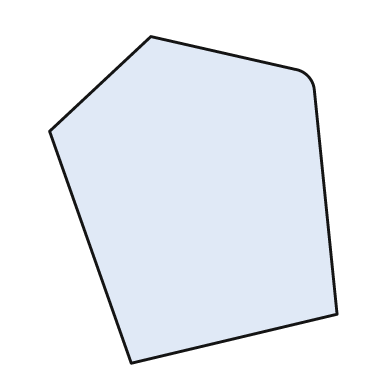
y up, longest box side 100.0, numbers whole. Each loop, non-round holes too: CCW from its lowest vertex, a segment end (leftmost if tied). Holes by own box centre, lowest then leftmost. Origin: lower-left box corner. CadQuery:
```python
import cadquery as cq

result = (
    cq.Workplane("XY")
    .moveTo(25.0, 0.0)
    .lineTo(88.0, 15.0)
    .lineTo(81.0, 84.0)
    .threePointArc((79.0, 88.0), (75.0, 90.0))
    .lineTo(31.0, 100.0)
    .lineTo(0.0, 71.0)
    .close()
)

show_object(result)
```